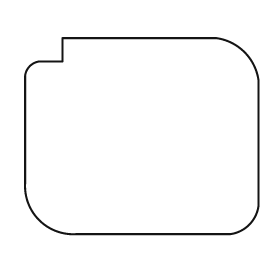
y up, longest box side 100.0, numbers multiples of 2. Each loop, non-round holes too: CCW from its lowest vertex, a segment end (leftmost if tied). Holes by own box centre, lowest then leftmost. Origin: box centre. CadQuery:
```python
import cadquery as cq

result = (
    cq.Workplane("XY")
    .moveTo(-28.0, -42.0)
    .lineTo(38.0, -42.0)
    .threePointArc((46.0, -38.0), (50.0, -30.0))
    .lineTo(50.0, 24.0)
    .threePointArc((44.0, 36.0), (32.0, 42.0))
    .lineTo(-34.0, 42.0)
    .lineTo(-34.0, 32.0)
    .lineTo(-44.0, 32.0)
    .threePointArc((-48.0, 30.0), (-50.0, 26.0))
    .lineTo(-50.0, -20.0)
    .threePointArc((-44.0, -36.0), (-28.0, -42.0))
    .close()
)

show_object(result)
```